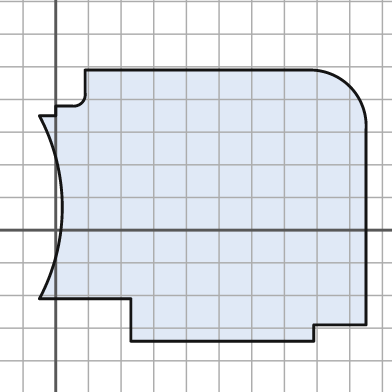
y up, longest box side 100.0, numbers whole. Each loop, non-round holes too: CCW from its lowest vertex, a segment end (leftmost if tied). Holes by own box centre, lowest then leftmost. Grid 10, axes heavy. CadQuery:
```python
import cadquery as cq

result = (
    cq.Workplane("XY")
    .moveTo(23.0, -34.0)
    .lineTo(79.0, -34.0)
    .lineTo(79.0, -29.0)
    .lineTo(95.0, -29.0)
    .lineTo(95.0, 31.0)
    .threePointArc((90.0, 44.0), (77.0, 49.0))
    .lineTo(9.0, 49.0)
    .lineTo(9.0, 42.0)
    .threePointArc((8.0, 39.0), (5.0, 38.0))
    .lineTo(0.0, 38.0)
    .lineTo(0.0, 35.0)
    .lineTo(-5.0, 35.0)
    .threePointArc((2.0, 7.0), (-5.0, -21.0))
    .lineTo(23.0, -21.0)
    .close()
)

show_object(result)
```